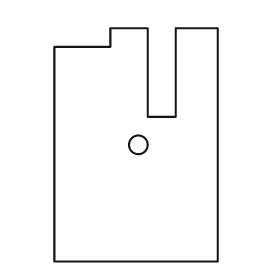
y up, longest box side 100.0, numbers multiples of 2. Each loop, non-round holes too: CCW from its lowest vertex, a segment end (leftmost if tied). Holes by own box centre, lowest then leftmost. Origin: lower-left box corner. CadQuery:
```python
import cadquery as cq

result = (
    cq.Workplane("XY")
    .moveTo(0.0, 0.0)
    .lineTo(70.0, 0.0)
    .lineTo(70.0, 100.0)
    .lineTo(52.0, 100.0)
    .lineTo(52.0, 62.0)
    .lineTo(40.0, 62.0)
    .lineTo(40.0, 100.0)
    .lineTo(24.0, 100.0)
    .lineTo(24.0, 92.0)
    .lineTo(0.0, 92.0)
    .close()
    .moveTo(36.0, 50.0)
    .circle(4.0)
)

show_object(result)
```